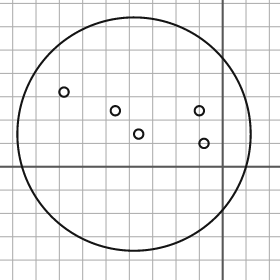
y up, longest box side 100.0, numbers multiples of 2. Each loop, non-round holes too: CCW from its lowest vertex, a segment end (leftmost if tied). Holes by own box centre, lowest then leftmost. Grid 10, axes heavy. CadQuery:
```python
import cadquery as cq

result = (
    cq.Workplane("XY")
    .moveTo(-38.0, 14.0)
    .circle(50.0)
    .moveTo(-8.0, 10.0)
    .circle(2.0)
    .moveTo(-36.0, 14.0)
    .circle(2.0)
    .moveTo(-46.0, 24.0)
    .circle(2.0)
    .moveTo(-10.0, 24.0)
    .circle(2.0)
    .moveTo(-68.0, 32.0)
    .circle(2.0)
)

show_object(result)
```